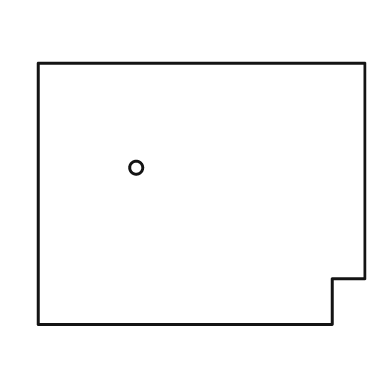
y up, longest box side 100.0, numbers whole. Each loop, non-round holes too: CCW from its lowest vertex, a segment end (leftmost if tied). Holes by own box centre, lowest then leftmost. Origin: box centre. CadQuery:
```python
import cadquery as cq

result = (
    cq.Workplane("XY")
    .moveTo(-50.0, -40.0)
    .lineTo(40.0, -40.0)
    .lineTo(40.0, -26.0)
    .lineTo(50.0, -26.0)
    .lineTo(50.0, 40.0)
    .lineTo(-50.0, 40.0)
    .close()
    .moveTo(-20.0, 8.0)
    .circle(2.0)
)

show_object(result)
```